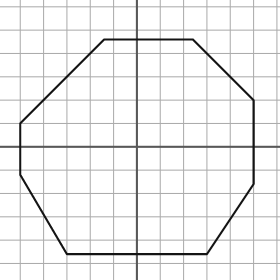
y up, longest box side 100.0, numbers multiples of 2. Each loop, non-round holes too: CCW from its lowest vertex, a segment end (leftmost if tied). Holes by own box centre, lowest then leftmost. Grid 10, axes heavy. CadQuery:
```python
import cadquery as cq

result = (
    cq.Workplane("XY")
    .moveTo(-30.0, -46.0)
    .lineTo(30.0, -46.0)
    .lineTo(50.0, -16.0)
    .lineTo(50.0, 20.0)
    .lineTo(24.0, 46.0)
    .lineTo(-14.0, 46.0)
    .lineTo(-50.0, 10.0)
    .lineTo(-50.0, -12.0)
    .close()
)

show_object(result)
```